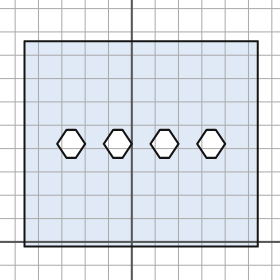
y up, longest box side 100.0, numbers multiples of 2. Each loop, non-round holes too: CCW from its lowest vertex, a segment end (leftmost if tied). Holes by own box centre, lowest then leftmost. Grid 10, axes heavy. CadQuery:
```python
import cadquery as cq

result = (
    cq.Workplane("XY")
    .moveTo(-46.0, -2.0)
    .lineTo(54.0, -2.0)
    .lineTo(54.0, 86.0)
    .lineTo(-46.0, 86.0)
    .close()
    .moveTo(-28.0, 36.0)
    .lineTo(-24.0, 36.0)
    .lineTo(-20.0, 42.0)
    .lineTo(-24.0, 48.0)
    .lineTo(-28.0, 48.0)
    .lineTo(-32.0, 42.0)
    .close()
    .moveTo(-8.0, 36.0)
    .lineTo(-4.0, 36.0)
    .lineTo(0.0, 42.0)
    .lineTo(-4.0, 48.0)
    .lineTo(-8.0, 48.0)
    .lineTo(-12.0, 42.0)
    .close()
    .moveTo(12.0, 36.0)
    .lineTo(16.0, 36.0)
    .lineTo(20.0, 42.0)
    .lineTo(16.0, 48.0)
    .lineTo(12.0, 48.0)
    .lineTo(8.0, 42.0)
    .close()
    .moveTo(32.0, 36.0)
    .lineTo(36.0, 36.0)
    .lineTo(40.0, 42.0)
    .lineTo(36.0, 48.0)
    .lineTo(32.0, 48.0)
    .lineTo(28.0, 42.0)
    .close()
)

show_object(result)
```